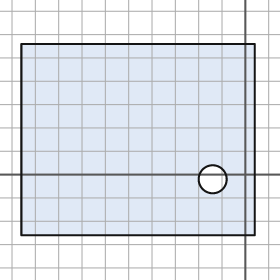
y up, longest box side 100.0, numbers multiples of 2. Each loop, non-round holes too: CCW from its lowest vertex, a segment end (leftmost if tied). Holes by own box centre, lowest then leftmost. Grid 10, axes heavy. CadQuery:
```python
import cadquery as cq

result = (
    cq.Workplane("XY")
    .moveTo(-96.0, -26.0)
    .lineTo(4.0, -26.0)
    .lineTo(4.0, 56.0)
    .lineTo(-96.0, 56.0)
    .close()
    .moveTo(-14.0, -2.0)
    .circle(6.0)
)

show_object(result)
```